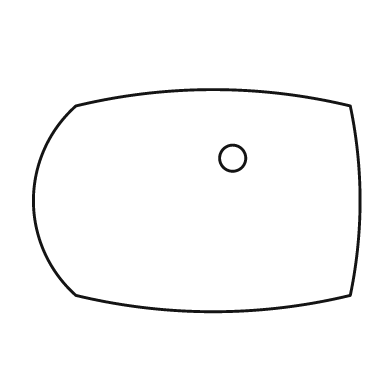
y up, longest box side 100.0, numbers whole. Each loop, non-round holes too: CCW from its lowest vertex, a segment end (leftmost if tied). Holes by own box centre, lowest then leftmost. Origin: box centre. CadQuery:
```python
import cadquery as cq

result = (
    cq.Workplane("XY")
    .moveTo(-37.0, -29.0)
    .threePointArc((5.0, -34.0), (47.0, -29.0))
    .threePointArc((50.0, 0.0), (47.0, 29.0))
    .threePointArc((5.0, 34.0), (-37.0, 29.0))
    .threePointArc((-50.0, 0.0), (-37.0, -29.0))
    .close()
    .moveTo(11.0, 13.0)
    .circle(4.0)
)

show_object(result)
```